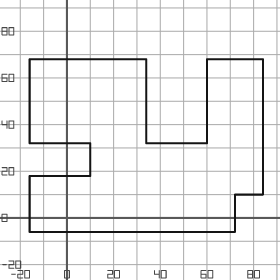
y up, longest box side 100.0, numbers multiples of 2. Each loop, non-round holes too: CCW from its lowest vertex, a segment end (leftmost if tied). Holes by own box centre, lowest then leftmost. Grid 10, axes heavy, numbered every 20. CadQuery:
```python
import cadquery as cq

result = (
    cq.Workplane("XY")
    .moveTo(-16.0, -6.0)
    .lineTo(72.0, -6.0)
    .lineTo(72.0, 10.0)
    .lineTo(84.0, 10.0)
    .lineTo(84.0, 68.0)
    .lineTo(60.0, 68.0)
    .lineTo(60.0, 32.0)
    .lineTo(34.0, 32.0)
    .lineTo(34.0, 68.0)
    .lineTo(-16.0, 68.0)
    .lineTo(-16.0, 32.0)
    .lineTo(10.0, 32.0)
    .lineTo(10.0, 18.0)
    .lineTo(-16.0, 18.0)
    .close()
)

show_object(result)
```